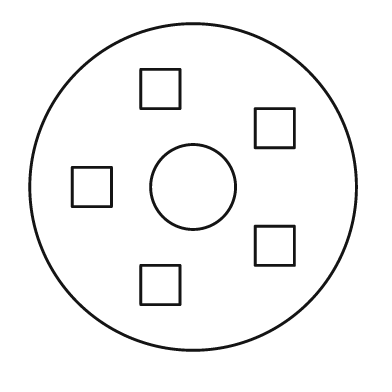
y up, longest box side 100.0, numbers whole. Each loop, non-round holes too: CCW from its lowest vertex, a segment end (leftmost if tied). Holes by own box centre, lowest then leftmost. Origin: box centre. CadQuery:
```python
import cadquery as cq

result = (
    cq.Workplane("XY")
    .moveTo(0.0, 0.0)
    .circle(50.0)
    .moveTo(-16.0, -36.0)
    .lineTo(-4.0, -36.0)
    .lineTo(-4.0, -24.0)
    .lineTo(-16.0, -24.0)
    .close()
    .moveTo(19.0, -24.0)
    .lineTo(31.0, -24.0)
    .lineTo(31.0, -12.0)
    .lineTo(19.0, -12.0)
    .close()
    .moveTo(-37.0, -6.0)
    .lineTo(-25.0, -6.0)
    .lineTo(-25.0, 6.0)
    .lineTo(-37.0, 6.0)
    .close()
    .moveTo(0.0, 0.0)
    .circle(13.0)
    .moveTo(19.0, 12.0)
    .lineTo(31.0, 12.0)
    .lineTo(31.0, 24.0)
    .lineTo(19.0, 24.0)
    .close()
    .moveTo(-16.0, 24.0)
    .lineTo(-4.0, 24.0)
    .lineTo(-4.0, 36.0)
    .lineTo(-16.0, 36.0)
    .close()
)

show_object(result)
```